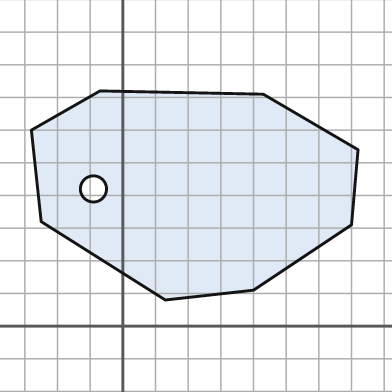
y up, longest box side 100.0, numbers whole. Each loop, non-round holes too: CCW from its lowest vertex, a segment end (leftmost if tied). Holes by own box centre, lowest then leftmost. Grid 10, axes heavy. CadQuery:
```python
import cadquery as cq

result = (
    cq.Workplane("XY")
    .moveTo(13.0, 8.0)
    .lineTo(40.0, 11.0)
    .lineTo(70.0, 31.0)
    .lineTo(72.0, 54.0)
    .lineTo(43.0, 71.0)
    .lineTo(-7.0, 72.0)
    .lineTo(-28.0, 60.0)
    .lineTo(-25.0, 32.0)
    .close()
    .moveTo(-9.0, 42.0)
    .circle(4.0)
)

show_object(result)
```